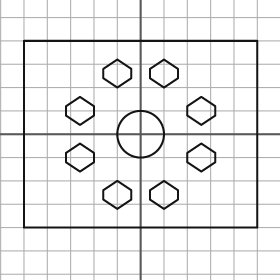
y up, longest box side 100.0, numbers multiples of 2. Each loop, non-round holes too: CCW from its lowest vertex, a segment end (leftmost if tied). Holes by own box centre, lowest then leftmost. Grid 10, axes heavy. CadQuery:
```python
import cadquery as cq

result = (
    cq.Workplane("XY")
    .moveTo(-50.0, -40.0)
    .lineTo(50.0, -40.0)
    .lineTo(50.0, 40.0)
    .lineTo(-50.0, 40.0)
    .close()
    .moveTo(-10.0, -32.0)
    .lineTo(-4.0, -28.0)
    .lineTo(-4.0, -24.0)
    .lineTo(-10.0, -20.0)
    .lineTo(-16.0, -24.0)
    .lineTo(-16.0, -28.0)
    .close()
    .moveTo(10.0, -32.0)
    .lineTo(16.0, -28.0)
    .lineTo(16.0, -24.0)
    .lineTo(10.0, -20.0)
    .lineTo(4.0, -24.0)
    .lineTo(4.0, -28.0)
    .close()
    .moveTo(-26.0, -16.0)
    .lineTo(-20.0, -12.0)
    .lineTo(-20.0, -8.0)
    .lineTo(-26.0, -4.0)
    .lineTo(-32.0, -8.0)
    .lineTo(-32.0, -12.0)
    .close()
    .moveTo(26.0, -16.0)
    .lineTo(32.0, -12.0)
    .lineTo(32.0, -8.0)
    .lineTo(26.0, -4.0)
    .lineTo(20.0, -8.0)
    .lineTo(20.0, -12.0)
    .close()
    .moveTo(0.0, 0.0)
    .circle(10.0)
    .moveTo(-26.0, 4.0)
    .lineTo(-20.0, 8.0)
    .lineTo(-20.0, 12.0)
    .lineTo(-26.0, 16.0)
    .lineTo(-32.0, 12.0)
    .lineTo(-32.0, 8.0)
    .close()
    .moveTo(26.0, 4.0)
    .lineTo(32.0, 8.0)
    .lineTo(32.0, 12.0)
    .lineTo(26.0, 16.0)
    .lineTo(20.0, 12.0)
    .lineTo(20.0, 8.0)
    .close()
    .moveTo(-10.0, 20.0)
    .lineTo(-4.0, 24.0)
    .lineTo(-4.0, 28.0)
    .lineTo(-10.0, 32.0)
    .lineTo(-16.0, 28.0)
    .lineTo(-16.0, 24.0)
    .close()
    .moveTo(10.0, 20.0)
    .lineTo(16.0, 24.0)
    .lineTo(16.0, 28.0)
    .lineTo(10.0, 32.0)
    .lineTo(4.0, 28.0)
    .lineTo(4.0, 24.0)
    .close()
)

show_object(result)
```